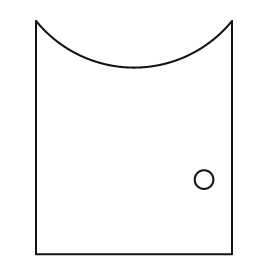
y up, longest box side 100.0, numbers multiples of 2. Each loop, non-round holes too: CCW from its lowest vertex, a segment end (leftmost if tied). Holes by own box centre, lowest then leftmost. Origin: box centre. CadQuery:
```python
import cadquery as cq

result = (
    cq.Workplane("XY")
    .moveTo(-42.0, -50.0)
    .lineTo(42.0, -50.0)
    .lineTo(42.0, 50.0)
    .threePointArc((0.0, 30.0), (-42.0, 50.0))
    .close()
    .moveTo(30.0, -18.0)
    .circle(4.0)
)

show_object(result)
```